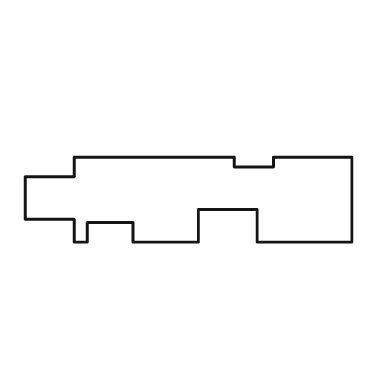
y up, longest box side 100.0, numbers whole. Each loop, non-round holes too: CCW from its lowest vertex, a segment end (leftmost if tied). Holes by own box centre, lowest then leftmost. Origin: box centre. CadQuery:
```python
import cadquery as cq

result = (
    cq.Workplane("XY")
    .moveTo(-35.0, -13.0)
    .lineTo(-31.0, -13.0)
    .lineTo(-31.0, -7.0)
    .lineTo(-17.0, -7.0)
    .lineTo(-17.0, -13.0)
    .lineTo(3.0, -13.0)
    .lineTo(3.0, -3.0)
    .lineTo(21.0, -3.0)
    .lineTo(21.0, -13.0)
    .lineTo(50.0, -13.0)
    .lineTo(50.0, 13.0)
    .lineTo(26.0, 13.0)
    .lineTo(26.0, 10.0)
    .lineTo(14.0, 10.0)
    .lineTo(14.0, 13.0)
    .lineTo(-35.0, 13.0)
    .lineTo(-35.0, 7.0)
    .lineTo(-50.0, 7.0)
    .lineTo(-50.0, -6.0)
    .lineTo(-35.0, -6.0)
    .close()
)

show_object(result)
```